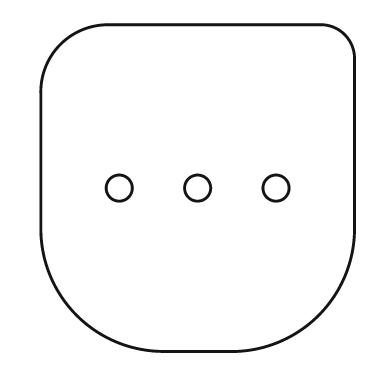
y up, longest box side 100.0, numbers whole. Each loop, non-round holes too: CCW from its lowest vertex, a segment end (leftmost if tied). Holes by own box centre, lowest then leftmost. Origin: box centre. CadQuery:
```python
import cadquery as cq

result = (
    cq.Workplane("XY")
    .moveTo(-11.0, -50.0)
    .lineTo(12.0, -50.0)
    .threePointArc((37.0, -39.0), (48.0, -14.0))
    .lineTo(48.0, 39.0)
    .threePointArc((45.0, 47.0), (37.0, 50.0))
    .lineTo(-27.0, 50.0)
    .threePointArc((-42.0, 44.0), (-48.0, 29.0))
    .lineTo(-48.0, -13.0)
    .threePointArc((-37.0, -39.0), (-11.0, -50.0))
    .close()
    .moveTo(-24.0, 0.0)
    .circle(4.0)
    .moveTo(0.0, 0.0)
    .circle(4.0)
    .moveTo(24.0, 0.0)
    .circle(4.0)
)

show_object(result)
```